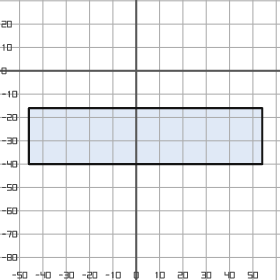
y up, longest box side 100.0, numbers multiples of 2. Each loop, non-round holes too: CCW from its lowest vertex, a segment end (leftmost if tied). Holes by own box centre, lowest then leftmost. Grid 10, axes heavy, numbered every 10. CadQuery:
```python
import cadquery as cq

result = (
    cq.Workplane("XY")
    .moveTo(-46.0, -40.0)
    .lineTo(54.0, -40.0)
    .lineTo(54.0, -16.0)
    .lineTo(-46.0, -16.0)
    .close()
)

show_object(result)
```